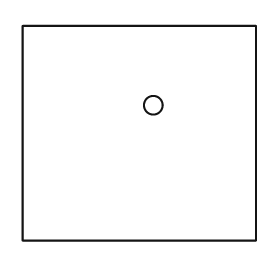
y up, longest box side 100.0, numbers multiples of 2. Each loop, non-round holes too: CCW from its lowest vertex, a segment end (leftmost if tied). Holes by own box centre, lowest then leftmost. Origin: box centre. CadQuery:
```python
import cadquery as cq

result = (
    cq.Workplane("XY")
    .moveTo(-50.0, -46.0)
    .lineTo(50.0, -46.0)
    .lineTo(50.0, 46.0)
    .lineTo(-50.0, 46.0)
    .close()
    .moveTo(6.0, 12.0)
    .circle(4.0)
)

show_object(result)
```